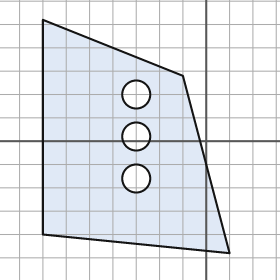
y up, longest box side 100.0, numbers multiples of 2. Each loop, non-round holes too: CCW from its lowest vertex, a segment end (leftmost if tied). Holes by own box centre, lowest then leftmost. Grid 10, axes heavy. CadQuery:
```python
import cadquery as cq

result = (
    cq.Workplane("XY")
    .moveTo(10.0, -48.0)
    .lineTo(-10.0, 28.0)
    .lineTo(-70.0, 52.0)
    .lineTo(-70.0, -40.0)
    .close()
    .moveTo(-30.0, -16.0)
    .circle(6.0)
    .moveTo(-30.0, 2.0)
    .circle(6.0)
    .moveTo(-30.0, 20.0)
    .circle(6.0)
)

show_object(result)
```